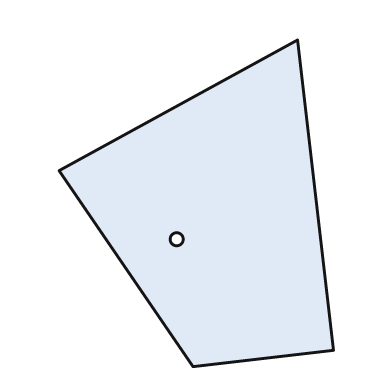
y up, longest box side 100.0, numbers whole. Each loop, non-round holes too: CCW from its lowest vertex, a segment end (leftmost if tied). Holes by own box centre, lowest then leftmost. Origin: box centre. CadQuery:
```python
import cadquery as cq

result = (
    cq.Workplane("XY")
    .moveTo(-1.0, -50.0)
    .lineTo(42.0, -45.0)
    .lineTo(31.0, 50.0)
    .lineTo(-42.0, 10.0)
    .close()
    .moveTo(-6.0, -11.0)
    .circle(2.0)
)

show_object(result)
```